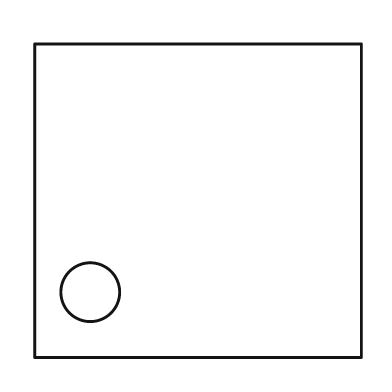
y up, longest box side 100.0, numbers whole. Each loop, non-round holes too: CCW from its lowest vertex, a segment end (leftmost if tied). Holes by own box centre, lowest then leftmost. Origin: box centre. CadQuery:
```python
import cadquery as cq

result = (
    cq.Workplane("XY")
    .moveTo(-50.0, -48.0)
    .lineTo(50.0, -48.0)
    .lineTo(50.0, 48.0)
    .lineTo(-50.0, 48.0)
    .close()
    .moveTo(-33.0, -28.0)
    .circle(9.0)
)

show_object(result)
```